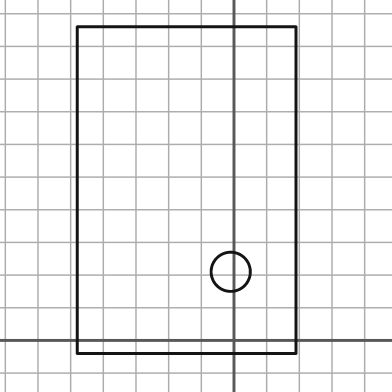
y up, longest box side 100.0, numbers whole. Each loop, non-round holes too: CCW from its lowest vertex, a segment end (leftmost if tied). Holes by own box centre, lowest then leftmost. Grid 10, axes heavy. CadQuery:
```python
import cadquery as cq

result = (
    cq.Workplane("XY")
    .moveTo(-48.0, -4.0)
    .lineTo(19.0, -4.0)
    .lineTo(19.0, 96.0)
    .lineTo(-48.0, 96.0)
    .close()
    .moveTo(-1.0, 21.0)
    .circle(6.0)
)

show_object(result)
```